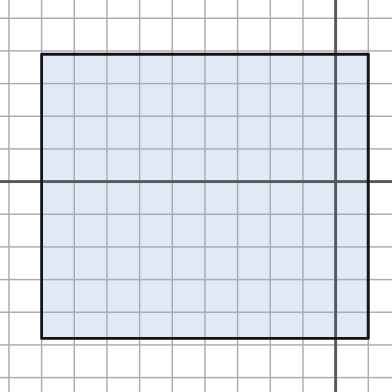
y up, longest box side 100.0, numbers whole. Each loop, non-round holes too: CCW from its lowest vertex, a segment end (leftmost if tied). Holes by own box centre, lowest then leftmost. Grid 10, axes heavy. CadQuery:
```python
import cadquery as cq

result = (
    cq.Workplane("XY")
    .moveTo(-90.0, -48.0)
    .lineTo(10.0, -48.0)
    .lineTo(10.0, 39.0)
    .lineTo(-90.0, 39.0)
    .close()
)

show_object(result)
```